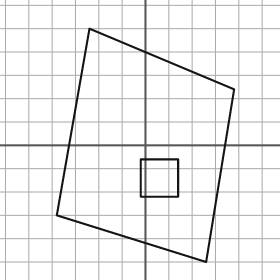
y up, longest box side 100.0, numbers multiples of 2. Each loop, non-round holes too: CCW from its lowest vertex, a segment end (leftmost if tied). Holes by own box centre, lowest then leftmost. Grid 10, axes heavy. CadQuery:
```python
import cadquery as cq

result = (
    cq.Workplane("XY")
    .moveTo(26.0, -50.0)
    .lineTo(38.0, 24.0)
    .lineTo(-24.0, 50.0)
    .lineTo(-38.0, -30.0)
    .close()
    .moveTo(-2.0, -22.0)
    .lineTo(14.0, -22.0)
    .lineTo(14.0, -6.0)
    .lineTo(-2.0, -6.0)
    .close()
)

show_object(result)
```